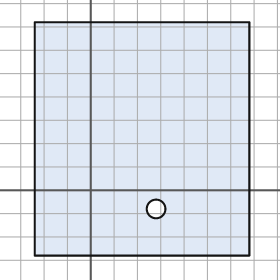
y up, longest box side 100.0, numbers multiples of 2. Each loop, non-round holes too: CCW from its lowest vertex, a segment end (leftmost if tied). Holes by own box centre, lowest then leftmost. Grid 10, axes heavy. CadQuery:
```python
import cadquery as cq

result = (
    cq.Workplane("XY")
    .moveTo(-24.0, -28.0)
    .lineTo(68.0, -28.0)
    .lineTo(68.0, 72.0)
    .lineTo(-24.0, 72.0)
    .close()
    .moveTo(28.0, -8.0)
    .circle(4.0)
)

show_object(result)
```